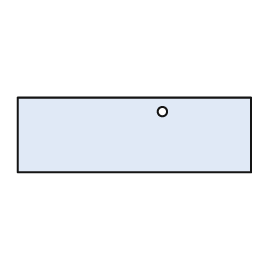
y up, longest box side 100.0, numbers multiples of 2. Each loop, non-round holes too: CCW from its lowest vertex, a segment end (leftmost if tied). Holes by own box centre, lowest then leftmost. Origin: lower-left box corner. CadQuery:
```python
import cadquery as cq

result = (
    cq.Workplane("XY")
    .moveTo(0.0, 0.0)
    .lineTo(100.0, 0.0)
    .lineTo(100.0, 32.0)
    .lineTo(0.0, 32.0)
    .close()
    .moveTo(62.0, 26.0)
    .circle(2.0)
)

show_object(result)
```